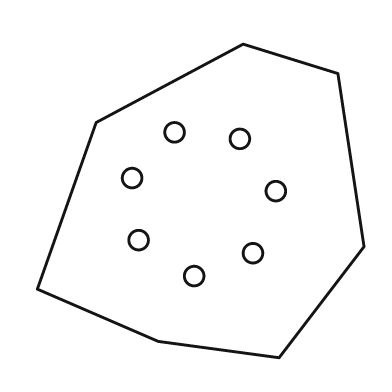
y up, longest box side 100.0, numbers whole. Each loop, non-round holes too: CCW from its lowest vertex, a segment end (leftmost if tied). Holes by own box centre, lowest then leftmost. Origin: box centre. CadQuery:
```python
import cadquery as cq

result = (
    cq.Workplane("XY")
    .moveTo(24.0, -48.0)
    .lineTo(50.0, -14.0)
    .lineTo(42.0, 39.0)
    .lineTo(13.0, 48.0)
    .lineTo(-32.0, 24.0)
    .lineTo(-50.0, -27.0)
    .lineTo(-13.0, -43.0)
    .close()
    .moveTo(-2.0, -23.0)
    .circle(3.0)
    .moveTo(16.0, -16.0)
    .circle(3.0)
    .moveTo(-19.0, -12.0)
    .circle(3.0)
    .moveTo(23.0, 3.0)
    .circle(3.0)
    .moveTo(-21.0, 7.0)
    .circle(3.0)
    .moveTo(12.0, 19.0)
    .circle(3.0)
    .moveTo(-8.0, 21.0)
    .circle(3.0)
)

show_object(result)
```